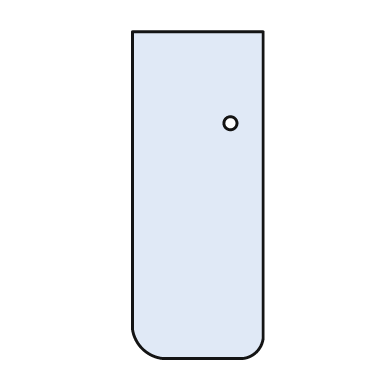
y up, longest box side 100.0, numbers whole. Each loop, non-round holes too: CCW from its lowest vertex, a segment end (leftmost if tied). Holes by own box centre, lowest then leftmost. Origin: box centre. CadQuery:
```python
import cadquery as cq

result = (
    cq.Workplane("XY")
    .moveTo(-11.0, -50.0)
    .lineTo(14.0, -50.0)
    .threePointArc((18.0, -48.0), (20.0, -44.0))
    .lineTo(20.0, 50.0)
    .lineTo(-20.0, 50.0)
    .lineTo(-20.0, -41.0)
    .threePointArc((-17.0, -47.0), (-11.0, -50.0))
    .close()
    .moveTo(10.0, 22.0)
    .circle(2.0)
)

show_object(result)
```